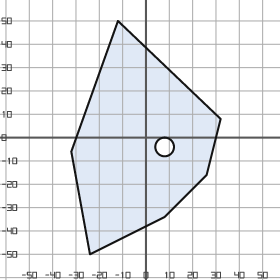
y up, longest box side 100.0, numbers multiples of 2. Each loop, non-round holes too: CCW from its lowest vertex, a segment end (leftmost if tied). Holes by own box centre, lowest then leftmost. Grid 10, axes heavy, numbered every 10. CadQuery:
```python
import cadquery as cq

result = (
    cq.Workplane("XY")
    .moveTo(-24.0, -50.0)
    .lineTo(8.0, -34.0)
    .lineTo(26.0, -16.0)
    .lineTo(32.0, 8.0)
    .lineTo(-12.0, 50.0)
    .lineTo(-32.0, -6.0)
    .close()
    .moveTo(8.0, -4.0)
    .circle(4.0)
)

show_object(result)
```